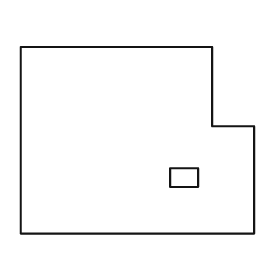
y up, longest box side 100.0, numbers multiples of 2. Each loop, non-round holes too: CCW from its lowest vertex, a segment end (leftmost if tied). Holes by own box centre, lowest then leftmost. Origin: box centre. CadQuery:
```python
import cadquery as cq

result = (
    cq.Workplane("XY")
    .moveTo(-50.0, -40.0)
    .lineTo(50.0, -40.0)
    .lineTo(50.0, 6.0)
    .lineTo(32.0, 6.0)
    .lineTo(32.0, 40.0)
    .lineTo(-50.0, 40.0)
    .close()
    .moveTo(14.0, -20.0)
    .lineTo(26.0, -20.0)
    .lineTo(26.0, -12.0)
    .lineTo(14.0, -12.0)
    .close()
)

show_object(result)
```